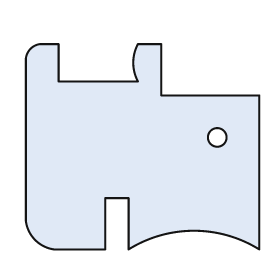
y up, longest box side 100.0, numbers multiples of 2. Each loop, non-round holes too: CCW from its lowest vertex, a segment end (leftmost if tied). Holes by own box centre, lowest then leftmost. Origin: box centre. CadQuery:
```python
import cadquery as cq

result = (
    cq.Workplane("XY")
    .moveTo(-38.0, -44.0)
    .lineTo(-16.0, -44.0)
    .lineTo(-16.0, -22.0)
    .lineTo(-6.0, -22.0)
    .lineTo(-6.0, -44.0)
    .threePointArc((22.0, -36.0), (50.0, -44.0))
    .lineTo(50.0, 22.0)
    .lineTo(8.0, 22.0)
    .lineTo(8.0, 44.0)
    .lineTo(-2.0, 44.0)
    .threePointArc((-4.0, 36.0), (-2.0, 28.0))
    .lineTo(-36.0, 28.0)
    .lineTo(-36.0, 44.0)
    .lineTo(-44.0, 44.0)
    .threePointArc((-48.0, 42.0), (-50.0, 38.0))
    .lineTo(-50.0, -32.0)
    .threePointArc((-46.0, -40.0), (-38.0, -44.0))
    .close()
    .moveTo(32.0, 4.0)
    .circle(4.0)
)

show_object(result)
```